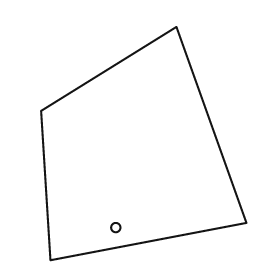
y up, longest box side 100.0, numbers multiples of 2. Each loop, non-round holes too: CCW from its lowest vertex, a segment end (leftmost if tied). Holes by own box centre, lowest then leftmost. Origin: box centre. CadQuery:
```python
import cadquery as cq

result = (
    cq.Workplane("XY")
    .moveTo(-40.0, -50.0)
    .lineTo(44.0, -34.0)
    .lineTo(14.0, 50.0)
    .lineTo(-44.0, 14.0)
    .close()
    .moveTo(-12.0, -36.0)
    .circle(2.0)
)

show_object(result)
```